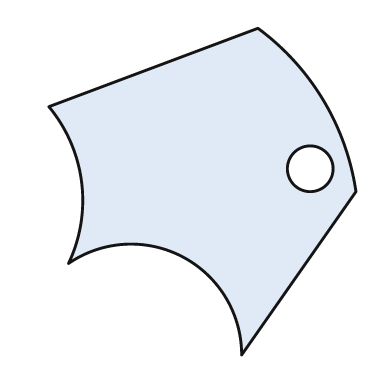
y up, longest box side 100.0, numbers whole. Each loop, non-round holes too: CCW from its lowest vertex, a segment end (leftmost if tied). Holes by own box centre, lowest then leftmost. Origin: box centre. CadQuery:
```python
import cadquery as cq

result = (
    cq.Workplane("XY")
    .moveTo(12.0, -50.0)
    .lineTo(47.0, 0.0)
    .threePointArc((37.0, 28.0), (17.0, 50.0))
    .lineTo(-47.0, 26.0)
    .threePointArc((-37.0, 3.0), (-41.0, -22.0))
    .threePointArc((-6.0, -20.0), (12.0, -50.0))
    .close()
    .moveTo(33.0, 7.0)
    .circle(7.0)
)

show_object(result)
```